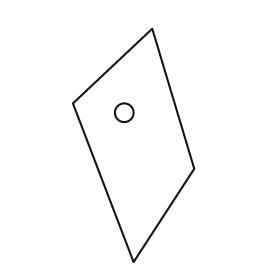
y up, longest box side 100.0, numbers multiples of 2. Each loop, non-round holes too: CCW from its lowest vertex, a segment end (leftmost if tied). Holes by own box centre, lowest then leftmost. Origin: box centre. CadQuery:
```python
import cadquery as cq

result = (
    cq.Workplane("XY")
    .moveTo(0.0, -50.0)
    .lineTo(26.0, -10.0)
    .lineTo(8.0, 50.0)
    .lineTo(-26.0, 18.0)
    .close()
    .moveTo(-4.0, 14.0)
    .circle(4.0)
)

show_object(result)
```